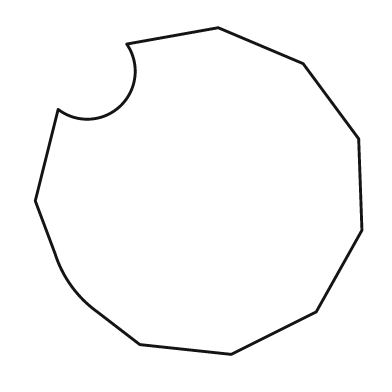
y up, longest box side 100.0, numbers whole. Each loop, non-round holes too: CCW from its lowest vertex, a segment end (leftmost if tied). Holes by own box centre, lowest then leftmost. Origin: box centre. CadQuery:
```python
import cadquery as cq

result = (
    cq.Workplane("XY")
    .moveTo(10.0, -50.0)
    .lineTo(36.0, -37.0)
    .lineTo(50.0, -12.0)
    .lineTo(49.0, 16.0)
    .lineTo(32.0, 39.0)
    .lineTo(6.0, 50.0)
    .lineTo(-22.0, 45.0)
    .threePointArc((-24.0, 26.0), (-43.0, 25.0))
    .lineTo(-50.0, -3.0)
    .lineTo(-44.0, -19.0)
    .threePointArc((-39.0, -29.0), (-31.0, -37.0))
    .lineTo(-18.0, -47.0)
    .close()
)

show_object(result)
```